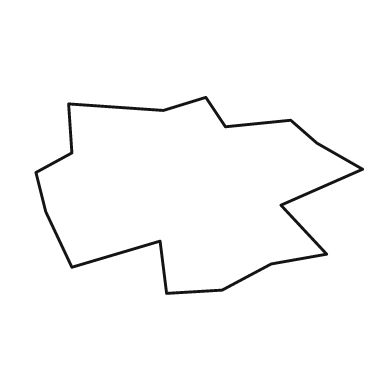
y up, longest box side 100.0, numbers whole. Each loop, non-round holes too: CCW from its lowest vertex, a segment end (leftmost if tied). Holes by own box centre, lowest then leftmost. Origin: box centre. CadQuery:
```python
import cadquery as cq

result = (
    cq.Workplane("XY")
    .moveTo(-10.0, -30.0)
    .lineTo(7.0, -29.0)
    .lineTo(22.0, -21.0)
    .lineTo(39.0, -18.0)
    .lineTo(25.0, -3.0)
    .lineTo(50.0, 8.0)
    .lineTo(36.0, 16.0)
    .lineTo(28.0, 23.0)
    .lineTo(8.0, 21.0)
    .lineTo(2.0, 30.0)
    .lineTo(-11.0, 26.0)
    .lineTo(-40.0, 28.0)
    .lineTo(-39.0, 13.0)
    .lineTo(-50.0, 7.0)
    .lineTo(-47.0, -5.0)
    .lineTo(-39.0, -22.0)
    .lineTo(-12.0, -14.0)
    .close()
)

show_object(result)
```